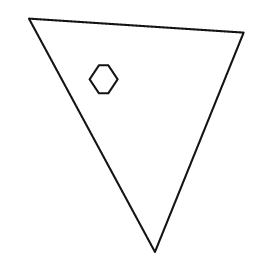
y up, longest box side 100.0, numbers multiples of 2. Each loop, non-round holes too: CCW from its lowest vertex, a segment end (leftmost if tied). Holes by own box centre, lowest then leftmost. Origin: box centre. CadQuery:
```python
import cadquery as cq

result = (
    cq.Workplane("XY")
    .moveTo(8.0, -50.0)
    .lineTo(46.0, 44.0)
    .lineTo(-46.0, 50.0)
    .close()
    .moveTo(-16.0, 18.0)
    .lineTo(-12.0, 18.0)
    .lineTo(-8.0, 24.0)
    .lineTo(-12.0, 30.0)
    .lineTo(-16.0, 30.0)
    .lineTo(-20.0, 24.0)
    .close()
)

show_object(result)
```